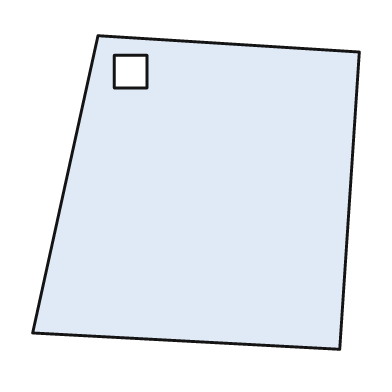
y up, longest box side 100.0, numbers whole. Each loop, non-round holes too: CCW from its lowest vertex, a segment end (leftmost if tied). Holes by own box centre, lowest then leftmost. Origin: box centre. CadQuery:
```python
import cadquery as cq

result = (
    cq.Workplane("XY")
    .moveTo(44.0, -48.0)
    .lineTo(50.0, 43.0)
    .lineTo(-30.0, 48.0)
    .lineTo(-50.0, -43.0)
    .close()
    .moveTo(-25.0, 32.0)
    .lineTo(-15.0, 32.0)
    .lineTo(-15.0, 42.0)
    .lineTo(-25.0, 42.0)
    .close()
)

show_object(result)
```